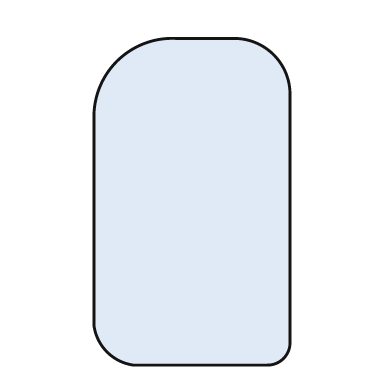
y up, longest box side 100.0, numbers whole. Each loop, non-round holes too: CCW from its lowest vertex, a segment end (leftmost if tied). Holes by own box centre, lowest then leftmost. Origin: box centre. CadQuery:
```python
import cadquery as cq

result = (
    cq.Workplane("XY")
    .moveTo(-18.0, -50.0)
    .lineTo(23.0, -50.0)
    .threePointArc((28.0, -48.0), (30.0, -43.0))
    .lineTo(30.0, 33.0)
    .threePointArc((25.0, 45.0), (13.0, 50.0))
    .lineTo(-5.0, 50.0)
    .threePointArc((-23.0, 43.0), (-30.0, 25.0))
    .lineTo(-30.0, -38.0)
    .threePointArc((-26.0, -46.0), (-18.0, -50.0))
    .close()
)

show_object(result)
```